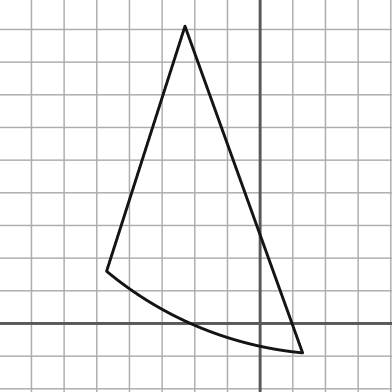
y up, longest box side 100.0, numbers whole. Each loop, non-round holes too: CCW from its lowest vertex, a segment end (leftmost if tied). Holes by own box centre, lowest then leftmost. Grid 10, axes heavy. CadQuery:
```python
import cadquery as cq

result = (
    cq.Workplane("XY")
    .moveTo(13.0, -9.0)
    .lineTo(-23.0, 91.0)
    .lineTo(-47.0, 16.0)
    .threePointArc((-19.0, -1.0), (13.0, -9.0))
    .close()
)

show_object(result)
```